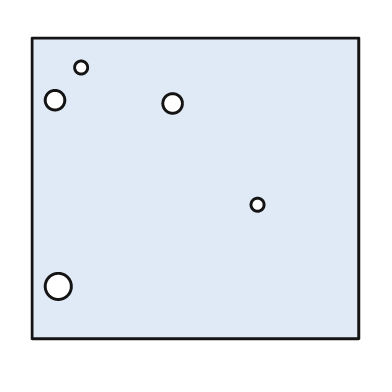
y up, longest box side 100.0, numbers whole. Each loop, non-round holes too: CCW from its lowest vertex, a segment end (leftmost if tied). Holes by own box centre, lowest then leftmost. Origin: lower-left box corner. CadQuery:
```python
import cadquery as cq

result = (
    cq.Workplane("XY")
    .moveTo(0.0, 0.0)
    .lineTo(100.0, 0.0)
    .lineTo(100.0, 92.0)
    .lineTo(0.0, 92.0)
    .close()
    .moveTo(8.0, 16.0)
    .circle(4.0)
    .moveTo(69.0, 41.0)
    .circle(2.0)
    .moveTo(43.0, 72.0)
    .circle(3.0)
    .moveTo(7.0, 73.0)
    .circle(3.0)
    .moveTo(15.0, 83.0)
    .circle(2.0)
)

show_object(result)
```